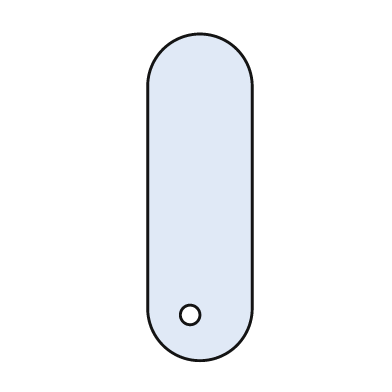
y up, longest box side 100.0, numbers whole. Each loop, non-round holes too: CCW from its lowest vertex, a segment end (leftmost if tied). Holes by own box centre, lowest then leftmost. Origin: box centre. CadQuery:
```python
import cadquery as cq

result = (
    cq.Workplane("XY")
    .moveTo(-16.0, -34.0)
    .threePointArc((0.0, -50.0), (16.0, -34.0))
    .lineTo(16.0, 34.0)
    .threePointArc((0.0, 50.0), (-16.0, 34.0))
    .close()
    .moveTo(-3.0, -36.0)
    .circle(3.0)
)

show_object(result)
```